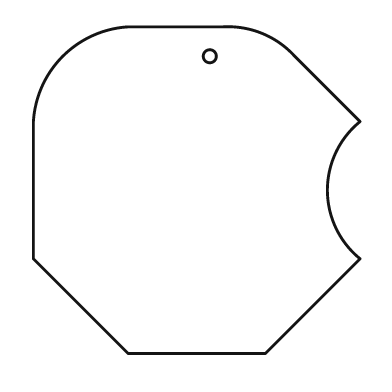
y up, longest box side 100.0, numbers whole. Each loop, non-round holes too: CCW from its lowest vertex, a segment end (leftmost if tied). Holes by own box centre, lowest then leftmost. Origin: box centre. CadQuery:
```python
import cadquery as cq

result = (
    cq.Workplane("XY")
    .moveTo(-21.0, -50.0)
    .lineTo(21.0, -50.0)
    .lineTo(50.0, -21.0)
    .threePointArc((40.0, 0.0), (50.0, 21.0))
    .lineTo(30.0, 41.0)
    .threePointArc((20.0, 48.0), (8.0, 50.0))
    .lineTo(-21.0, 50.0)
    .threePointArc((-41.0, 41.0), (-50.0, 21.0))
    .lineTo(-50.0, -21.0)
    .close()
    .moveTo(4.0, 41.0)
    .circle(2.0)
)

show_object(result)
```